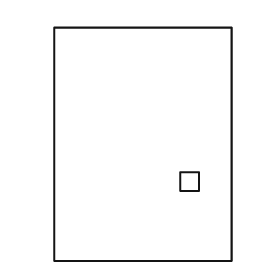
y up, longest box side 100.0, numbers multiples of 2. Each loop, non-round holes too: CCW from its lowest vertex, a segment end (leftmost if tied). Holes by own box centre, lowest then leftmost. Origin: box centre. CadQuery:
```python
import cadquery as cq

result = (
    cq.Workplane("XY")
    .moveTo(-38.0, -50.0)
    .lineTo(38.0, -50.0)
    .lineTo(38.0, 50.0)
    .lineTo(-38.0, 50.0)
    .close()
    .moveTo(16.0, -20.0)
    .lineTo(24.0, -20.0)
    .lineTo(24.0, -12.0)
    .lineTo(16.0, -12.0)
    .close()
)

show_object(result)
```